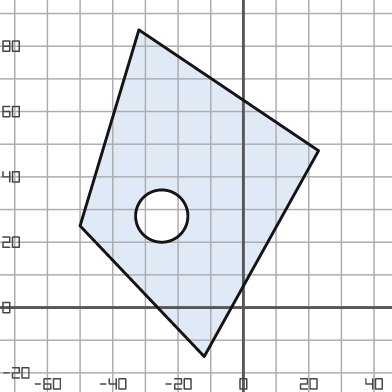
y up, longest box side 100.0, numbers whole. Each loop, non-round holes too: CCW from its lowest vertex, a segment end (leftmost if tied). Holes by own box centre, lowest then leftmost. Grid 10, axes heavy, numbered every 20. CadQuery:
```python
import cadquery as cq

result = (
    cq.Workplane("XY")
    .moveTo(-12.0, -15.0)
    .lineTo(23.0, 48.0)
    .lineTo(-32.0, 85.0)
    .lineTo(-50.0, 25.0)
    .close()
    .moveTo(-25.0, 28.0)
    .circle(8.0)
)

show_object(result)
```